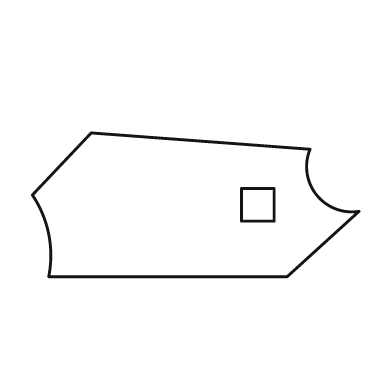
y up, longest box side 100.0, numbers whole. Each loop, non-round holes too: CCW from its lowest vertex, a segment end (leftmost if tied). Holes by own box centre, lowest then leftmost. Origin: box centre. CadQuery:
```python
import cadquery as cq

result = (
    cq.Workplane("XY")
    .moveTo(-45.0, -22.0)
    .lineTo(28.0, -22.0)
    .lineTo(50.0, -2.0)
    .threePointArc((37.0, 3.0), (35.0, 17.0))
    .lineTo(-32.0, 22.0)
    .lineTo(-50.0, 3.0)
    .threePointArc((-45.0, -9.0), (-45.0, -22.0))
    .close()
    .moveTo(14.0, -5.0)
    .lineTo(24.0, -5.0)
    .lineTo(24.0, 5.0)
    .lineTo(14.0, 5.0)
    .close()
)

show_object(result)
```